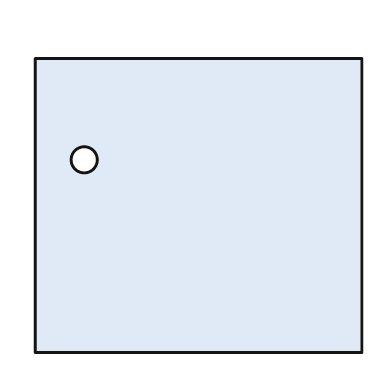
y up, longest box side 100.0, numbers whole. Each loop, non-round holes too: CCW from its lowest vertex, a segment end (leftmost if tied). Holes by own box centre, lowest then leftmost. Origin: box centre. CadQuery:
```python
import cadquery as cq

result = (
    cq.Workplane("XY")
    .moveTo(-50.0, -45.0)
    .lineTo(50.0, -45.0)
    .lineTo(50.0, 45.0)
    .lineTo(-50.0, 45.0)
    .close()
    .moveTo(-35.0, 14.0)
    .circle(4.0)
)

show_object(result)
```